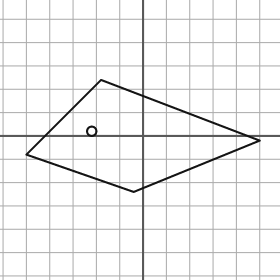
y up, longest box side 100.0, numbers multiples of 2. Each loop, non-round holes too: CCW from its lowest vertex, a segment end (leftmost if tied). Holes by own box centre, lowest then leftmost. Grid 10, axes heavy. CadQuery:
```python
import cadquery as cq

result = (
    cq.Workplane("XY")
    .moveTo(-4.0, -24.0)
    .lineTo(50.0, -2.0)
    .lineTo(-18.0, 24.0)
    .lineTo(-50.0, -8.0)
    .close()
    .moveTo(-22.0, 2.0)
    .circle(2.0)
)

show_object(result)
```